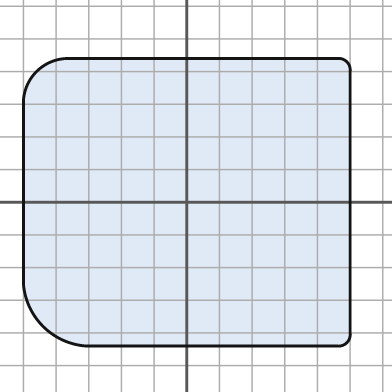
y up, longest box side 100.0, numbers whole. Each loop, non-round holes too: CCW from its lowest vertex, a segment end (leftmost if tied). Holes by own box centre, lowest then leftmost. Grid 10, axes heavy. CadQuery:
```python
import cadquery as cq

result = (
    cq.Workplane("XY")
    .moveTo(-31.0, -44.0)
    .lineTo(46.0, -44.0)
    .threePointArc((49.0, -43.0), (50.0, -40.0))
    .lineTo(50.0, 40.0)
    .threePointArc((49.0, 43.0), (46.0, 44.0))
    .lineTo(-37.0, 44.0)
    .threePointArc((-46.0, 40.0), (-50.0, 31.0))
    .lineTo(-50.0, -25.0)
    .threePointArc((-44.0, -38.0), (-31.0, -44.0))
    .close()
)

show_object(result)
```